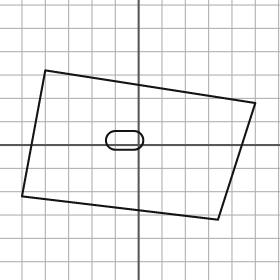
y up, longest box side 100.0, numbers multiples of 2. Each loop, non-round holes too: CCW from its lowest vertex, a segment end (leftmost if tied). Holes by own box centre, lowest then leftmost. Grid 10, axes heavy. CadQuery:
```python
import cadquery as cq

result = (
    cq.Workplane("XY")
    .moveTo(34.0, -32.0)
    .lineTo(50.0, 18.0)
    .lineTo(-40.0, 32.0)
    .lineTo(-50.0, -22.0)
    .close()
    .moveTo(-10.0, -2.0)
    .lineTo(-2.0, -2.0)
    .threePointArc((2.0, 2.0), (-2.0, 6.0))
    .lineTo(-10.0, 6.0)
    .threePointArc((-14.0, 2.0), (-10.0, -2.0))
    .close()
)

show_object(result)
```